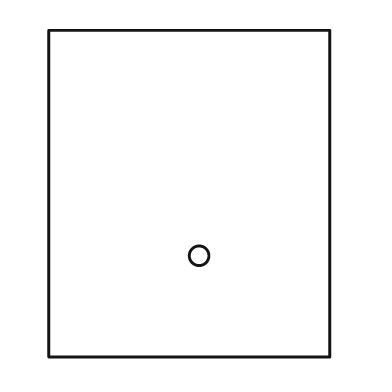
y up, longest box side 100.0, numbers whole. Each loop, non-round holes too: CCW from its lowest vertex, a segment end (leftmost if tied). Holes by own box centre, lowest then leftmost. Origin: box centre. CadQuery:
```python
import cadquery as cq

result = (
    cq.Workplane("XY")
    .moveTo(-43.0, -50.0)
    .lineTo(43.0, -50.0)
    .lineTo(43.0, 50.0)
    .lineTo(-43.0, 50.0)
    .close()
    .moveTo(3.0, -19.0)
    .circle(3.0)
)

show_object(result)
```